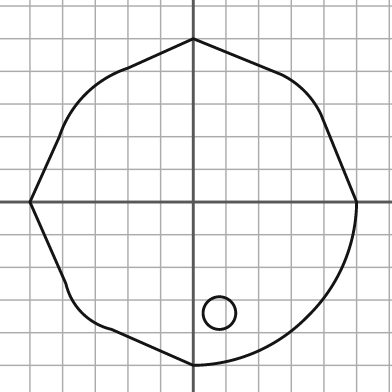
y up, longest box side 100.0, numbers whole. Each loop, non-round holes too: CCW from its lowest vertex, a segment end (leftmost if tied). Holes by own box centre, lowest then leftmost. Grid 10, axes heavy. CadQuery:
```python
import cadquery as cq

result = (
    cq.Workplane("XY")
    .moveTo(0.0, -50.0)
    .threePointArc((19.0, -46.0), (35.0, -35.0))
    .threePointArc((46.0, -19.0), (50.0, 0.0))
    .lineTo(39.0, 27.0)
    .threePointArc((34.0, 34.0), (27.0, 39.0))
    .lineTo(0.0, 50.0)
    .lineTo(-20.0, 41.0)
    .threePointArc((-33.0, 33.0), (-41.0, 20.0))
    .lineTo(-50.0, 0.0)
    .lineTo(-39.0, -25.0)
    .threePointArc((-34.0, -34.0), (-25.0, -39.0))
    .close()
    .moveTo(8.0, -34.0)
    .circle(5.0)
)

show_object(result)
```